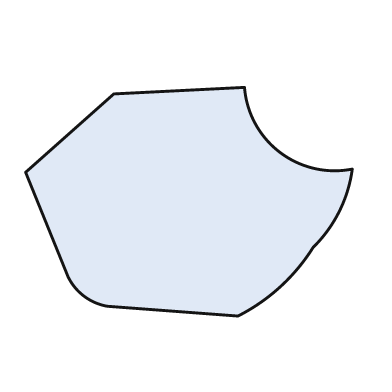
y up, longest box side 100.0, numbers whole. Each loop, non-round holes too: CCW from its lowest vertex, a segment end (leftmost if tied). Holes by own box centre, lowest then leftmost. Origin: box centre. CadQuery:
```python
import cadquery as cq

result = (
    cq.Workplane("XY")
    .moveTo(15.0, -35.0)
    .threePointArc((28.0, -26.0), (38.0, -14.0))
    .threePointArc((46.0, -3.0), (50.0, 10.0))
    .threePointArc((28.0, 15.0), (17.0, 35.0))
    .lineTo(-23.0, 33.0)
    .lineTo(-50.0, 9.0)
    .lineTo(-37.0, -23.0)
    .threePointArc((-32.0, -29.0), (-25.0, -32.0))
    .close()
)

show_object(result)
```